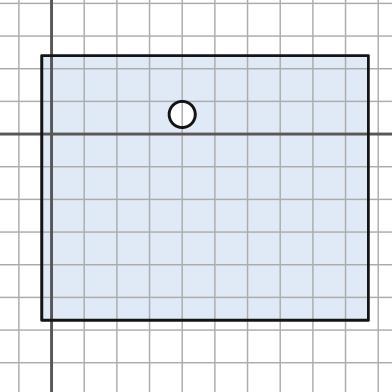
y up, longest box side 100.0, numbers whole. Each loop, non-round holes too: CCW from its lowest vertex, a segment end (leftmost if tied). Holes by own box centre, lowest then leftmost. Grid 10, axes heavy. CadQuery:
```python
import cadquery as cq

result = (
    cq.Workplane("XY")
    .moveTo(-3.0, -57.0)
    .lineTo(97.0, -57.0)
    .lineTo(97.0, 24.0)
    .lineTo(-3.0, 24.0)
    .close()
    .moveTo(40.0, 6.0)
    .circle(4.0)
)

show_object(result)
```